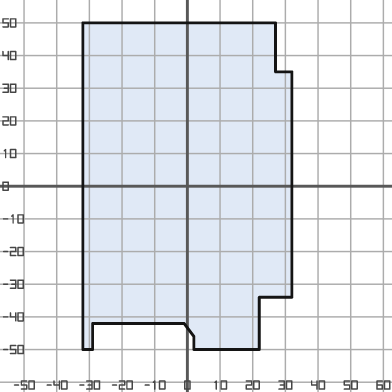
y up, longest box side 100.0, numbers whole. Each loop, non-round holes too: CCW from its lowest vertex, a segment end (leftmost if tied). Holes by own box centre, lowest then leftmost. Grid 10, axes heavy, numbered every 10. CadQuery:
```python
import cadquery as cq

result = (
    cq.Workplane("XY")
    .moveTo(-32.0, -50.0)
    .lineTo(-29.0, -50.0)
    .lineTo(-29.0, -42.0)
    .lineTo(-1.0, -42.0)
    .lineTo(2.0, -46.0)
    .lineTo(2.0, -50.0)
    .lineTo(22.0, -50.0)
    .lineTo(22.0, -34.0)
    .lineTo(32.0, -34.0)
    .lineTo(32.0, 35.0)
    .lineTo(27.0, 35.0)
    .lineTo(27.0, 50.0)
    .lineTo(-32.0, 50.0)
    .close()
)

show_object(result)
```